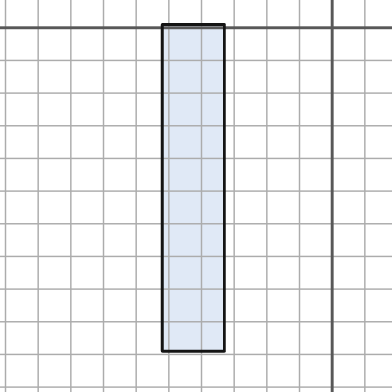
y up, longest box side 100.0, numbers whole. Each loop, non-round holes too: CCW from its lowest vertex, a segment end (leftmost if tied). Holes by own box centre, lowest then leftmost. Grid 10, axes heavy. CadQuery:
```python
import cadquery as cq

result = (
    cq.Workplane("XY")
    .moveTo(-52.0, -99.0)
    .lineTo(-33.0, -99.0)
    .lineTo(-33.0, 1.0)
    .lineTo(-52.0, 1.0)
    .close()
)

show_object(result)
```